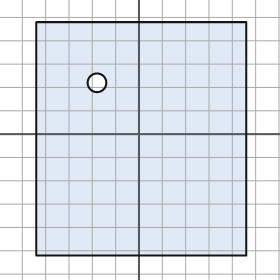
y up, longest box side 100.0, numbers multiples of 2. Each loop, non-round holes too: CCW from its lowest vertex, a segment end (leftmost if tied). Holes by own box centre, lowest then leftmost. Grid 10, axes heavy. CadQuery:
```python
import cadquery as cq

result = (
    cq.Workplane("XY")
    .moveTo(-44.0, -52.0)
    .lineTo(46.0, -52.0)
    .lineTo(46.0, 48.0)
    .lineTo(-44.0, 48.0)
    .close()
    .moveTo(-18.0, 22.0)
    .circle(4.0)
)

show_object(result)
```